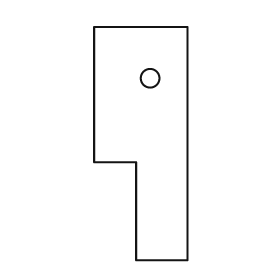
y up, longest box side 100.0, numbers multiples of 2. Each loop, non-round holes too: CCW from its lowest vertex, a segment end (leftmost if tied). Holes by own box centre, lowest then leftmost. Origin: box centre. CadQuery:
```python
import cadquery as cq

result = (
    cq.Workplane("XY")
    .moveTo(-2.0, -50.0)
    .lineTo(20.0, -50.0)
    .lineTo(20.0, 50.0)
    .lineTo(-20.0, 50.0)
    .lineTo(-20.0, -8.0)
    .lineTo(-2.0, -8.0)
    .close()
    .moveTo(4.0, 28.0)
    .circle(4.0)
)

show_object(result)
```